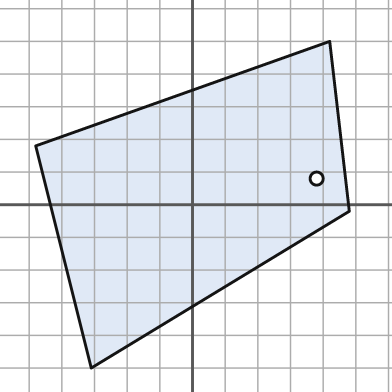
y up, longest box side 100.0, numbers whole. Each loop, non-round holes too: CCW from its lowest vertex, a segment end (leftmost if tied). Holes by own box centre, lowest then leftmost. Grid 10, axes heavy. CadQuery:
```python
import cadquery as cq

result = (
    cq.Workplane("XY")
    .moveTo(-31.0, -50.0)
    .lineTo(48.0, -2.0)
    .lineTo(42.0, 50.0)
    .lineTo(-48.0, 18.0)
    .close()
    .moveTo(38.0, 8.0)
    .circle(2.0)
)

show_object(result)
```